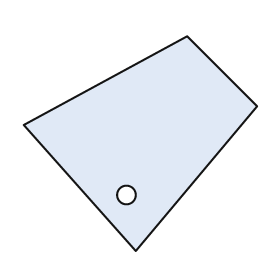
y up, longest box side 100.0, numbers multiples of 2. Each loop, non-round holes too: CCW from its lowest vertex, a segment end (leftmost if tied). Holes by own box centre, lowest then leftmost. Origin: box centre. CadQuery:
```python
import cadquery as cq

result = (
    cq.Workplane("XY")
    .moveTo(-2.0, -46.0)
    .lineTo(50.0, 16.0)
    .lineTo(20.0, 46.0)
    .lineTo(-50.0, 8.0)
    .close()
    .moveTo(-6.0, -22.0)
    .circle(4.0)
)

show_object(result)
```